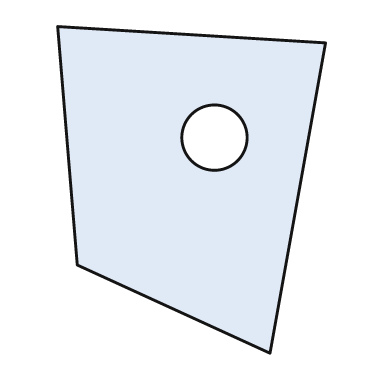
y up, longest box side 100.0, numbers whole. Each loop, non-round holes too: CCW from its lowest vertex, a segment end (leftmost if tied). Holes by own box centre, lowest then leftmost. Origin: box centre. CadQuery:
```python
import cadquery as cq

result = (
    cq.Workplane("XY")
    .moveTo(24.0, -50.0)
    .lineTo(41.0, 45.0)
    .lineTo(-41.0, 50.0)
    .lineTo(-35.0, -23.0)
    .close()
    .moveTo(7.0, 16.0)
    .circle(10.0)
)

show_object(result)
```